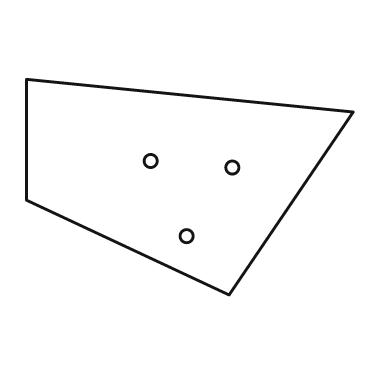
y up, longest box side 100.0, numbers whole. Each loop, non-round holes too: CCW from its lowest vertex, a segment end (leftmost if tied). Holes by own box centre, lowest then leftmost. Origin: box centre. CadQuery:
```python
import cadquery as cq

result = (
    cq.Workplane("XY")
    .moveTo(12.0, -33.0)
    .lineTo(50.0, 23.0)
    .lineTo(-50.0, 33.0)
    .lineTo(-50.0, -4.0)
    .close()
    .moveTo(-1.0, -15.0)
    .circle(2.0)
    .moveTo(13.0, 6.0)
    .circle(2.0)
    .moveTo(-12.0, 8.0)
    .circle(2.0)
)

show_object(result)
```